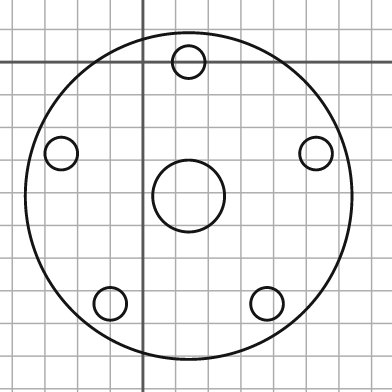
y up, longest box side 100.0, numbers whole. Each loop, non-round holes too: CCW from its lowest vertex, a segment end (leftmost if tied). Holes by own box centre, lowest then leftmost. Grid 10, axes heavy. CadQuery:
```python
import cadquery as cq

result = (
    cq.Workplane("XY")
    .moveTo(14.0, -41.0)
    .circle(50.0)
    .moveTo(-10.0, -74.0)
    .circle(5.0)
    .moveTo(38.0, -74.0)
    .circle(5.0)
    .moveTo(14.0, -41.0)
    .circle(11.0)
    .moveTo(-25.0, -28.0)
    .circle(5.0)
    .moveTo(53.0, -28.0)
    .circle(5.0)
    .moveTo(14.0, 0.0)
    .circle(5.0)
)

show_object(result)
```